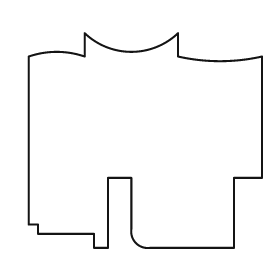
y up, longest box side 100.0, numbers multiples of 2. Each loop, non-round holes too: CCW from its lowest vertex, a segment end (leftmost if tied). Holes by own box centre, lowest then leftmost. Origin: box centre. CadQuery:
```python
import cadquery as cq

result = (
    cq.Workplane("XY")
    .moveTo(-22.0, -46.0)
    .lineTo(-16.0, -46.0)
    .lineTo(-16.0, -16.0)
    .lineTo(-6.0, -16.0)
    .lineTo(-6.0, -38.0)
    .threePointArc((-4.0, -44.0), (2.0, -46.0))
    .lineTo(38.0, -46.0)
    .lineTo(38.0, -16.0)
    .lineTo(50.0, -16.0)
    .lineTo(50.0, 36.0)
    .threePointArc((32.0, 34.0), (14.0, 36.0))
    .lineTo(14.0, 46.0)
    .threePointArc((-6.0, 38.0), (-26.0, 46.0))
    .lineTo(-26.0, 36.0)
    .threePointArc((-38.0, 38.0), (-50.0, 36.0))
    .lineTo(-50.0, -36.0)
    .lineTo(-46.0, -36.0)
    .lineTo(-46.0, -40.0)
    .lineTo(-22.0, -40.0)
    .close()
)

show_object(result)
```